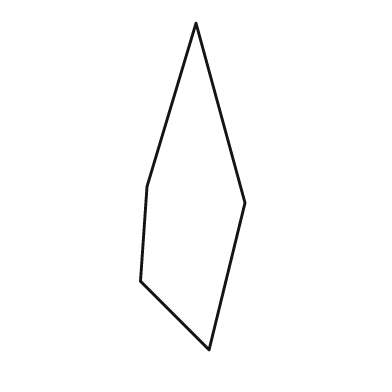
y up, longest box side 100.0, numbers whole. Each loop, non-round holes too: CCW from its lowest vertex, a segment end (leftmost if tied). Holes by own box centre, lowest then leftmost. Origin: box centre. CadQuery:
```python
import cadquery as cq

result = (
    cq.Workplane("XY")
    .moveTo(5.0, -50.0)
    .lineTo(16.0, -5.0)
    .lineTo(1.0, 50.0)
    .lineTo(-14.0, 0.0)
    .lineTo(-16.0, -29.0)
    .close()
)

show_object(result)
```